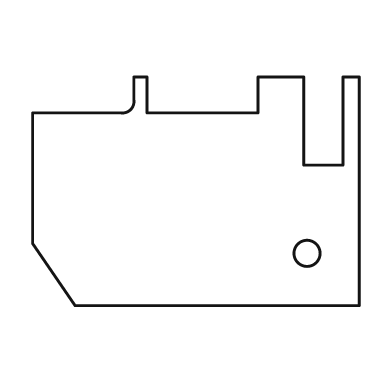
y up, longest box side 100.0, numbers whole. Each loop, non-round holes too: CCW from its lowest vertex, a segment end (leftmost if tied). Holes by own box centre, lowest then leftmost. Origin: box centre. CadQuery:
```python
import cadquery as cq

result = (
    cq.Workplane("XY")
    .moveTo(-37.0, -35.0)
    .lineTo(50.0, -35.0)
    .lineTo(50.0, 35.0)
    .lineTo(45.0, 35.0)
    .lineTo(45.0, 8.0)
    .lineTo(33.0, 8.0)
    .lineTo(33.0, 35.0)
    .lineTo(19.0, 35.0)
    .lineTo(19.0, 24.0)
    .lineTo(-15.0, 24.0)
    .lineTo(-15.0, 35.0)
    .lineTo(-19.0, 35.0)
    .lineTo(-19.0, 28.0)
    .threePointArc((-20.0, 25.0), (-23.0, 24.0))
    .lineTo(-50.0, 24.0)
    .lineTo(-50.0, -16.0)
    .close()
    .moveTo(34.0, -19.0)
    .circle(4.0)
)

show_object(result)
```